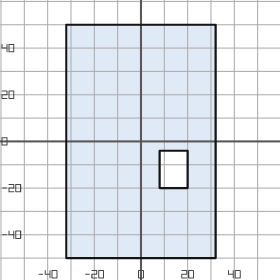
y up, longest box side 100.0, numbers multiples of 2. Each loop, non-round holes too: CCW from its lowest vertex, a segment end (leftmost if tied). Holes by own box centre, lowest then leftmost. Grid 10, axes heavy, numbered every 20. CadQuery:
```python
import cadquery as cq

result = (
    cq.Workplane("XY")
    .moveTo(-32.0, -50.0)
    .lineTo(32.0, -50.0)
    .lineTo(32.0, 50.0)
    .lineTo(-32.0, 50.0)
    .close()
    .moveTo(8.0, -20.0)
    .lineTo(20.0, -20.0)
    .lineTo(20.0, -4.0)
    .lineTo(8.0, -4.0)
    .close()
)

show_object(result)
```